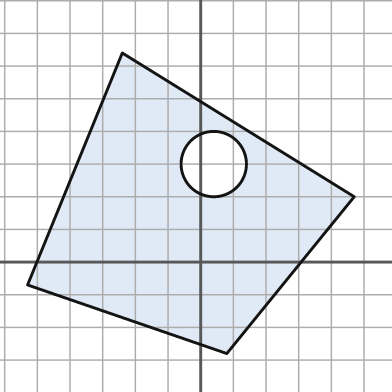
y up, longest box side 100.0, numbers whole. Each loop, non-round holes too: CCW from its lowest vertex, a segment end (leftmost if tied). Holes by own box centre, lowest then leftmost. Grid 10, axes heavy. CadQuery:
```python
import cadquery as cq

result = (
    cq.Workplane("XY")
    .moveTo(8.0, -28.0)
    .lineTo(47.0, 20.0)
    .lineTo(-24.0, 64.0)
    .lineTo(-53.0, -7.0)
    .close()
    .moveTo(4.0, 30.0)
    .circle(10.0)
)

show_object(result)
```